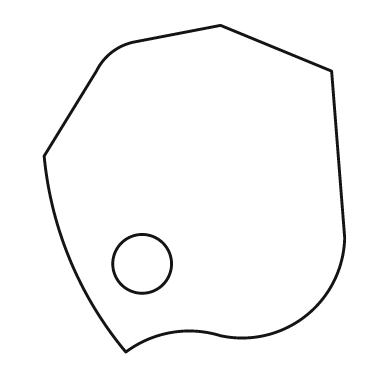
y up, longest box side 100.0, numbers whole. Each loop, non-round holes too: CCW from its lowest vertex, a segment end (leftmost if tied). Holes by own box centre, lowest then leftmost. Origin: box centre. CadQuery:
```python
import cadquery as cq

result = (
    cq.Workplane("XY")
    .moveTo(-21.0, -50.0)
    .threePointArc((-7.0, -44.0), (8.0, -45.0))
    .threePointArc((34.0, -39.0), (46.0, -15.0))
    .lineTo(42.0, 36.0)
    .lineTo(8.0, 50.0)
    .lineTo(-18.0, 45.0)
    .threePointArc((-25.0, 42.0), (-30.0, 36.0))
    .lineTo(-46.0, 10.0)
    .threePointArc((-38.0, -22.0), (-21.0, -50.0))
    .close()
    .moveTo(-16.0, -23.0)
    .circle(9.0)
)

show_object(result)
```